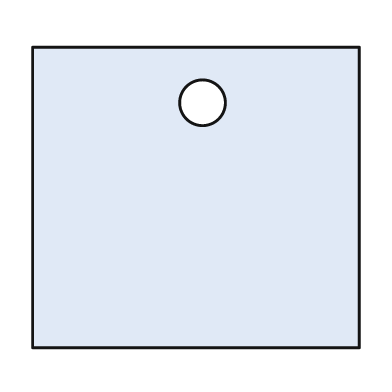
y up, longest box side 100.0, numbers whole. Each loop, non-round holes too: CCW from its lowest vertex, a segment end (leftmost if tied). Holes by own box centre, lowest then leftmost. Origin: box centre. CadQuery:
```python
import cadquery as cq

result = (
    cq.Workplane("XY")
    .moveTo(-50.0, -46.0)
    .lineTo(50.0, -46.0)
    .lineTo(50.0, 46.0)
    .lineTo(-50.0, 46.0)
    .close()
    .moveTo(2.0, 29.0)
    .circle(7.0)
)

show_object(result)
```